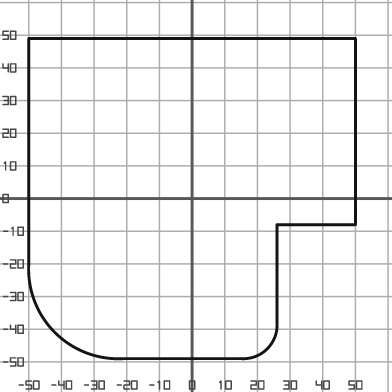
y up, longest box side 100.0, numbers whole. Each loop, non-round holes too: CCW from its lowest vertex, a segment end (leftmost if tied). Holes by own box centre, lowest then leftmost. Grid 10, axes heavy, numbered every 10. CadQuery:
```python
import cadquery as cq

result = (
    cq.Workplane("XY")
    .moveTo(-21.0, -49.0)
    .lineTo(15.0, -49.0)
    .threePointArc((23.0, -46.0), (26.0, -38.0))
    .lineTo(26.0, -8.0)
    .lineTo(50.0, -8.0)
    .lineTo(50.0, 49.0)
    .lineTo(-50.0, 49.0)
    .lineTo(-50.0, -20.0)
    .threePointArc((-42.0, -41.0), (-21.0, -49.0))
    .close()
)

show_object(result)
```